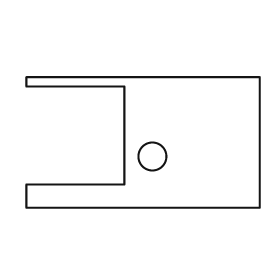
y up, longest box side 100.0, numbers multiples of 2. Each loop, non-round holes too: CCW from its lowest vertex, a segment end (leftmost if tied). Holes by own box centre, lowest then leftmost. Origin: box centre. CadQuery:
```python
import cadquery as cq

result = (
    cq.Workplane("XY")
    .moveTo(-50.0, -28.0)
    .lineTo(50.0, -28.0)
    .lineTo(50.0, 28.0)
    .lineTo(-50.0, 28.0)
    .lineTo(-50.0, 24.0)
    .lineTo(-8.0, 24.0)
    .lineTo(-8.0, -18.0)
    .lineTo(-50.0, -18.0)
    .close()
    .moveTo(4.0, -6.0)
    .circle(6.0)
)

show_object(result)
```